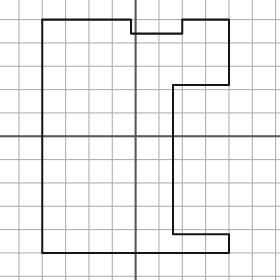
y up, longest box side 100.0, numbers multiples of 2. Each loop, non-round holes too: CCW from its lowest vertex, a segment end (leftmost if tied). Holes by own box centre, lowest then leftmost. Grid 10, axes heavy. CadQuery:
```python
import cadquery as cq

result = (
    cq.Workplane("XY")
    .moveTo(-40.0, -50.0)
    .lineTo(40.0, -50.0)
    .lineTo(40.0, -42.0)
    .lineTo(16.0, -42.0)
    .lineTo(16.0, 22.0)
    .lineTo(40.0, 22.0)
    .lineTo(40.0, 50.0)
    .lineTo(20.0, 50.0)
    .lineTo(20.0, 44.0)
    .lineTo(-2.0, 44.0)
    .lineTo(-2.0, 50.0)
    .lineTo(-40.0, 50.0)
    .close()
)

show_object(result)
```